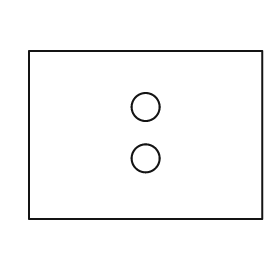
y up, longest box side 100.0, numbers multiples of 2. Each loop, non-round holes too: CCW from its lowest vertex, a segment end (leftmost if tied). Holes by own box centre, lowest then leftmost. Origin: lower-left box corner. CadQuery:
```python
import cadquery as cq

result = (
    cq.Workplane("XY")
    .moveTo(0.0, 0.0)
    .lineTo(100.0, 0.0)
    .lineTo(100.0, 72.0)
    .lineTo(0.0, 72.0)
    .close()
    .moveTo(50.0, 26.0)
    .circle(6.0)
    .moveTo(50.0, 48.0)
    .circle(6.0)
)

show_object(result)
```